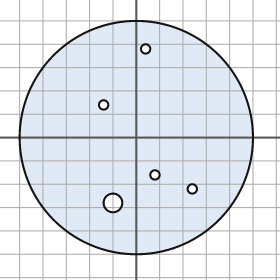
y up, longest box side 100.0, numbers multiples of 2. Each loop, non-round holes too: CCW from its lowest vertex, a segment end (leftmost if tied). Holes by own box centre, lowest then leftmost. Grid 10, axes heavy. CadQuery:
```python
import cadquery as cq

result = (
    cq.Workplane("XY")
    .moveTo(0.0, 0.0)
    .circle(50.0)
    .moveTo(-10.0, -28.0)
    .circle(4.0)
    .moveTo(24.0, -22.0)
    .circle(2.0)
    .moveTo(8.0, -16.0)
    .circle(2.0)
    .moveTo(-14.0, 14.0)
    .circle(2.0)
    .moveTo(4.0, 38.0)
    .circle(2.0)
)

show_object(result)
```